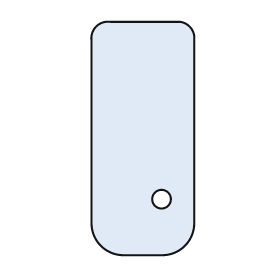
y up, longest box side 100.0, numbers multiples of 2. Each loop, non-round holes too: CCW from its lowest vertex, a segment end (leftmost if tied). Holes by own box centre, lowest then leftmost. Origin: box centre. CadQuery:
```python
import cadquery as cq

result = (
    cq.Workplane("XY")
    .moveTo(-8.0, -50.0)
    .lineTo(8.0, -50.0)
    .threePointArc((18.0, -46.0), (22.0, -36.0))
    .lineTo(22.0, 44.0)
    .threePointArc((20.0, 48.0), (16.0, 50.0))
    .lineTo(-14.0, 50.0)
    .threePointArc((-20.0, 48.0), (-22.0, 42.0))
    .lineTo(-22.0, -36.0)
    .threePointArc((-18.0, -46.0), (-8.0, -50.0))
    .close()
    .moveTo(8.0, -26.0)
    .circle(4.0)
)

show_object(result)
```